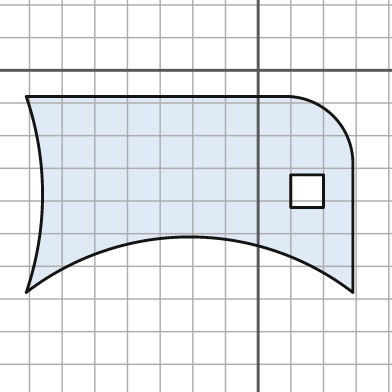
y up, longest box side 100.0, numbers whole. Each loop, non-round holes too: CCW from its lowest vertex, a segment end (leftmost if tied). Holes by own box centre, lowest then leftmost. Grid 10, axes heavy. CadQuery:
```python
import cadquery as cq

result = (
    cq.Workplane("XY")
    .moveTo(-71.0, -68.0)
    .threePointArc((-21.0, -51.0), (29.0, -68.0))
    .lineTo(29.0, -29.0)
    .threePointArc((23.0, -14.0), (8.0, -8.0))
    .lineTo(-71.0, -8.0)
    .threePointArc((-66.0, -38.0), (-71.0, -68.0))
    .close()
    .moveTo(10.0, -42.0)
    .lineTo(20.0, -42.0)
    .lineTo(20.0, -32.0)
    .lineTo(10.0, -32.0)
    .close()
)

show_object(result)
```